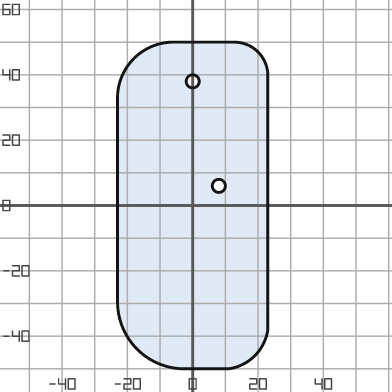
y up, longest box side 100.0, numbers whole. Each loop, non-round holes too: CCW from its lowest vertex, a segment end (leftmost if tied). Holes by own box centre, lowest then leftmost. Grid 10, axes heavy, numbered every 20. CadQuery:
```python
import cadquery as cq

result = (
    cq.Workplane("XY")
    .moveTo(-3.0, -50.0)
    .lineTo(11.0, -50.0)
    .threePointArc((19.0, -46.0), (23.0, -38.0))
    .lineTo(23.0, 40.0)
    .threePointArc((20.0, 47.0), (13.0, 50.0))
    .lineTo(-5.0, 50.0)
    .threePointArc((-18.0, 45.0), (-23.0, 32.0))
    .lineTo(-23.0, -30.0)
    .threePointArc((-17.0, -44.0), (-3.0, -50.0))
    .close()
    .moveTo(8.0, 6.0)
    .circle(2.0)
    .moveTo(0.0, 38.0)
    .circle(2.0)
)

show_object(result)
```